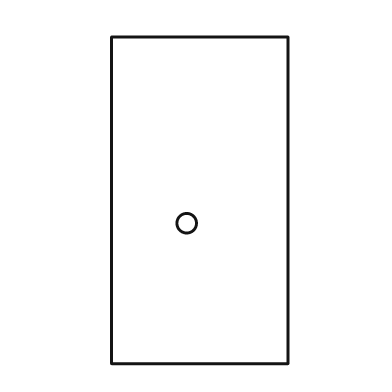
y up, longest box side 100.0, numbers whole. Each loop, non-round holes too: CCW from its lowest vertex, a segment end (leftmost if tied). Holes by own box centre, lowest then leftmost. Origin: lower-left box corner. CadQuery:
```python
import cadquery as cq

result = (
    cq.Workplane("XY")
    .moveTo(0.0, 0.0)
    .lineTo(54.0, 0.0)
    .lineTo(54.0, 100.0)
    .lineTo(0.0, 100.0)
    .close()
    .moveTo(23.0, 43.0)
    .circle(3.0)
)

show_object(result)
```